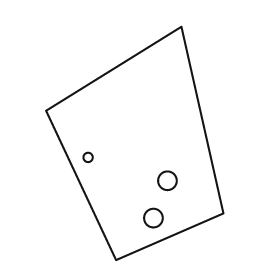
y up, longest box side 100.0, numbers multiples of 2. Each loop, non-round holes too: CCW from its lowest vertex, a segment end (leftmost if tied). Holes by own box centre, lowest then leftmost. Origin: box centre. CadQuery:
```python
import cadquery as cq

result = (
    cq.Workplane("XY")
    .moveTo(-8.0, -50.0)
    .lineTo(38.0, -30.0)
    .lineTo(20.0, 50.0)
    .lineTo(-38.0, 14.0)
    .close()
    .moveTo(8.0, -32.0)
    .circle(4.0)
    .moveTo(14.0, -16.0)
    .circle(4.0)
    .moveTo(-20.0, -6.0)
    .circle(2.0)
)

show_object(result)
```